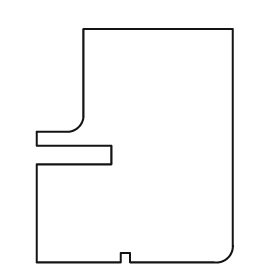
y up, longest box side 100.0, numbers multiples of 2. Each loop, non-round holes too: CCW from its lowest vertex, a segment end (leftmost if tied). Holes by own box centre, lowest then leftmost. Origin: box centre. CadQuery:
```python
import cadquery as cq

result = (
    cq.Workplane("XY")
    .moveTo(-42.0, -50.0)
    .lineTo(-6.0, -50.0)
    .lineTo(-6.0, -46.0)
    .lineTo(-2.0, -46.0)
    .lineTo(-2.0, -50.0)
    .lineTo(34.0, -50.0)
    .threePointArc((40.0, -48.0), (42.0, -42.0))
    .lineTo(42.0, 50.0)
    .lineTo(-22.0, 50.0)
    .lineTo(-22.0, 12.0)
    .threePointArc((-24.0, 8.0), (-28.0, 6.0))
    .lineTo(-42.0, 6.0)
    .lineTo(-42.0, 0.0)
    .lineTo(-10.0, 0.0)
    .lineTo(-10.0, -8.0)
    .lineTo(-42.0, -8.0)
    .close()
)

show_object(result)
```